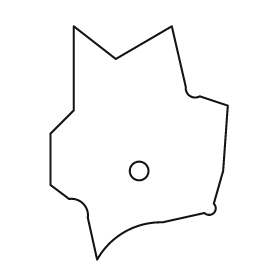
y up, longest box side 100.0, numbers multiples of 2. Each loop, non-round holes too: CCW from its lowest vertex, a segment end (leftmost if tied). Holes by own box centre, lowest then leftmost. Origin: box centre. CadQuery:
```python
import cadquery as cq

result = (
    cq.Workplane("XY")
    .moveTo(-18.0, -50.0)
    .threePointArc((-6.0, -38.0), (10.0, -34.0))
    .lineTo(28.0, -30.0)
    .threePointArc((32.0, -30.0), (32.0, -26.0))
    .lineTo(36.0, -12.0)
    .lineTo(38.0, 16.0)
    .lineTo(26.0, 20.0)
    .threePointArc((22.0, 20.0), (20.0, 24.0))
    .lineTo(14.0, 50.0)
    .lineTo(-10.0, 36.0)
    .lineTo(-28.0, 50.0)
    .lineTo(-28.0, 14.0)
    .lineTo(-38.0, 4.0)
    .lineTo(-38.0, -18.0)
    .lineTo(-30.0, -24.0)
    .threePointArc((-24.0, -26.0), (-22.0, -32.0))
    .close()
    .moveTo(0.0, -12.0)
    .circle(4.0)
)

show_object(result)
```